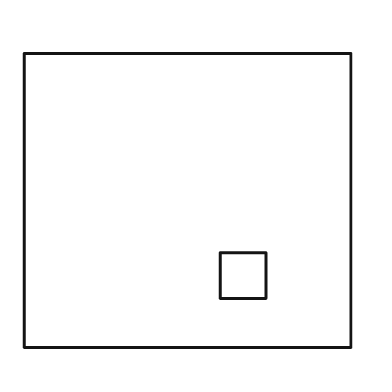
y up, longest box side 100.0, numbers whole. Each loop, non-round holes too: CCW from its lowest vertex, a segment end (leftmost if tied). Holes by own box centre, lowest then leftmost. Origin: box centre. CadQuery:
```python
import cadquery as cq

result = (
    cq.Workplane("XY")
    .moveTo(-50.0, -45.0)
    .lineTo(50.0, -45.0)
    .lineTo(50.0, 45.0)
    .lineTo(-50.0, 45.0)
    .close()
    .moveTo(10.0, -30.0)
    .lineTo(24.0, -30.0)
    .lineTo(24.0, -16.0)
    .lineTo(10.0, -16.0)
    .close()
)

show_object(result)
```